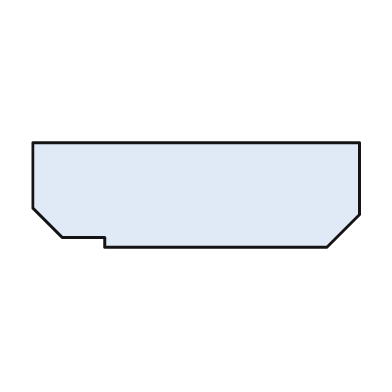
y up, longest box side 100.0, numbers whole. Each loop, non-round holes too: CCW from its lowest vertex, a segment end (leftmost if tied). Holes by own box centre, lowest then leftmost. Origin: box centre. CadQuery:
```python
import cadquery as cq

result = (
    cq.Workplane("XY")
    .moveTo(-28.0, -16.0)
    .lineTo(40.0, -16.0)
    .lineTo(50.0, -6.0)
    .lineTo(50.0, 16.0)
    .lineTo(-50.0, 16.0)
    .lineTo(-50.0, -4.0)
    .lineTo(-41.0, -13.0)
    .lineTo(-28.0, -13.0)
    .close()
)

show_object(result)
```